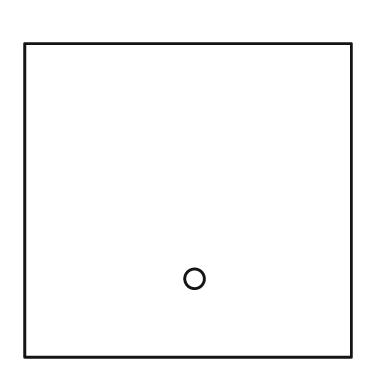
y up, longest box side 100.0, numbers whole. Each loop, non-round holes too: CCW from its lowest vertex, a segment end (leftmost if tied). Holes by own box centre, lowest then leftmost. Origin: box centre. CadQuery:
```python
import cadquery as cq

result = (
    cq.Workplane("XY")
    .moveTo(-50.0, -48.0)
    .lineTo(50.0, -48.0)
    .lineTo(50.0, 48.0)
    .lineTo(-50.0, 48.0)
    .close()
    .moveTo(2.0, -24.0)
    .circle(3.0)
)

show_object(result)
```